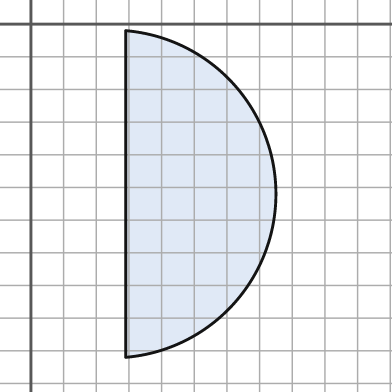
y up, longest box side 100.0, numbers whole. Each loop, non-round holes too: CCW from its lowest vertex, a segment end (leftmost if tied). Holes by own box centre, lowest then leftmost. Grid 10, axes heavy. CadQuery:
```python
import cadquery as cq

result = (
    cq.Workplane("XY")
    .moveTo(29.0, -102.0)
    .threePointArc((75.0, -52.0), (29.0, -2.0))
    .close()
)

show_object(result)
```